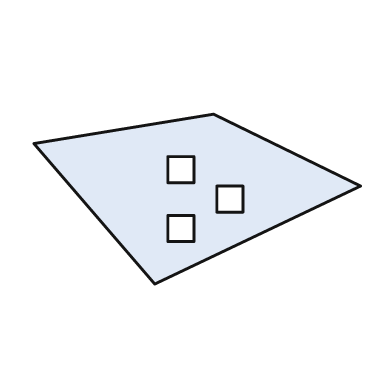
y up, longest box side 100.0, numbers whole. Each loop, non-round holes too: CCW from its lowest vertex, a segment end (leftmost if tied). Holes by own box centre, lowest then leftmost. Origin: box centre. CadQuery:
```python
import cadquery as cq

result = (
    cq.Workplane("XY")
    .moveTo(-13.0, -26.0)
    .lineTo(50.0, 4.0)
    .lineTo(5.0, 26.0)
    .lineTo(-50.0, 17.0)
    .close()
    .moveTo(-9.0, -13.0)
    .lineTo(-1.0, -13.0)
    .lineTo(-1.0, -5.0)
    .lineTo(-9.0, -5.0)
    .close()
    .moveTo(6.0, -4.0)
    .lineTo(14.0, -4.0)
    .lineTo(14.0, 4.0)
    .lineTo(6.0, 4.0)
    .close()
    .moveTo(-9.0, 5.0)
    .lineTo(-1.0, 5.0)
    .lineTo(-1.0, 13.0)
    .lineTo(-9.0, 13.0)
    .close()
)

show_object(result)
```